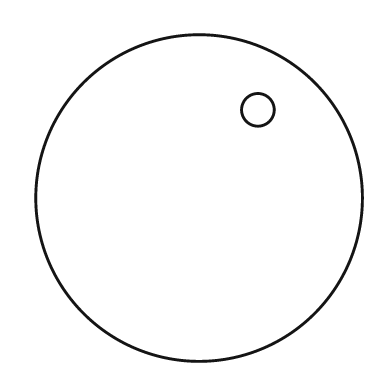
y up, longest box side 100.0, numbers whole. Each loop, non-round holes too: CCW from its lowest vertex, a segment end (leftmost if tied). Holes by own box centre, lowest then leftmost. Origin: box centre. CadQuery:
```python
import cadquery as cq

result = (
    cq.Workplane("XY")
    .moveTo(0.0, 0.0)
    .circle(50.0)
    .moveTo(18.0, 27.0)
    .circle(5.0)
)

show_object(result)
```